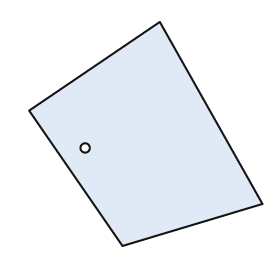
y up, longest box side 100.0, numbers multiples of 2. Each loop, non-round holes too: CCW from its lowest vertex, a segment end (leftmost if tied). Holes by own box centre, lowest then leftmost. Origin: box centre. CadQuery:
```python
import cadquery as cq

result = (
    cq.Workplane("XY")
    .moveTo(-10.0, -48.0)
    .lineTo(50.0, -30.0)
    .lineTo(6.0, 48.0)
    .lineTo(-50.0, 10.0)
    .close()
    .moveTo(-26.0, -6.0)
    .circle(2.0)
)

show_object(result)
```